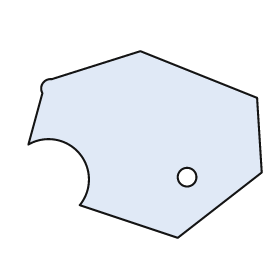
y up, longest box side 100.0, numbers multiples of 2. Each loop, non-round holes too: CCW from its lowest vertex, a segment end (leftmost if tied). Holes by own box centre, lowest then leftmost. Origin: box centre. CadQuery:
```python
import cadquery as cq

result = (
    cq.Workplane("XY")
    .moveTo(14.0, -40.0)
    .lineTo(50.0, -12.0)
    .lineTo(48.0, 20.0)
    .lineTo(-2.0, 40.0)
    .lineTo(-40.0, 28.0)
    .threePointArc((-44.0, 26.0), (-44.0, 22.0))
    .lineTo(-50.0, 0.0)
    .threePointArc((-28.0, -4.0), (-28.0, -26.0))
    .close()
    .moveTo(18.0, -14.0)
    .circle(4.0)
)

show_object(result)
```